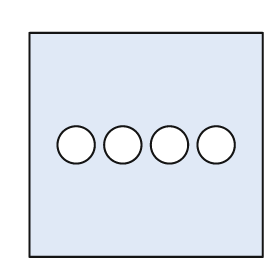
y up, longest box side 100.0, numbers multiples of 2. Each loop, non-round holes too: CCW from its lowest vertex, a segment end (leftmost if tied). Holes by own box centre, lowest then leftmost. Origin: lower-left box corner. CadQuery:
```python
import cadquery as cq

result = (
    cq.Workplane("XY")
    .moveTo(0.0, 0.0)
    .lineTo(100.0, 0.0)
    .lineTo(100.0, 96.0)
    .lineTo(0.0, 96.0)
    .close()
    .moveTo(20.0, 48.0)
    .circle(8.0)
    .moveTo(40.0, 48.0)
    .circle(8.0)
    .moveTo(60.0, 48.0)
    .circle(8.0)
    .moveTo(80.0, 48.0)
    .circle(8.0)
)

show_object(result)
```